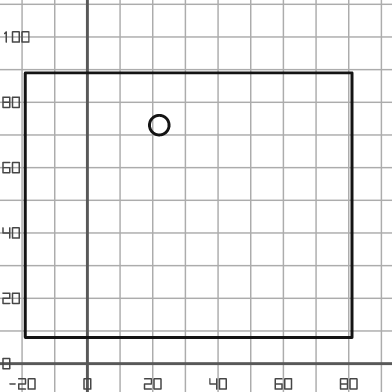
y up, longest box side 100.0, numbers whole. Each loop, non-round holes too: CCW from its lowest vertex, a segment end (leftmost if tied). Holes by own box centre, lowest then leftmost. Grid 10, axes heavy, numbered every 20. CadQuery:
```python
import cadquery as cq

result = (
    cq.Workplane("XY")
    .moveTo(-19.0, 8.0)
    .lineTo(81.0, 8.0)
    .lineTo(81.0, 89.0)
    .lineTo(-19.0, 89.0)
    .close()
    .moveTo(22.0, 73.0)
    .circle(3.0)
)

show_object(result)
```